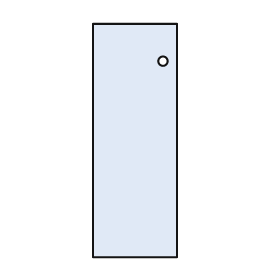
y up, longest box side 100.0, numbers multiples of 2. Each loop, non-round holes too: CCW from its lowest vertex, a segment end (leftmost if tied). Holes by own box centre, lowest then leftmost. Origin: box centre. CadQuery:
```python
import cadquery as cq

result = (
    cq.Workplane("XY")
    .moveTo(-18.0, -50.0)
    .lineTo(18.0, -50.0)
    .lineTo(18.0, 50.0)
    .lineTo(-18.0, 50.0)
    .close()
    .moveTo(12.0, 34.0)
    .circle(2.0)
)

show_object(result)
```